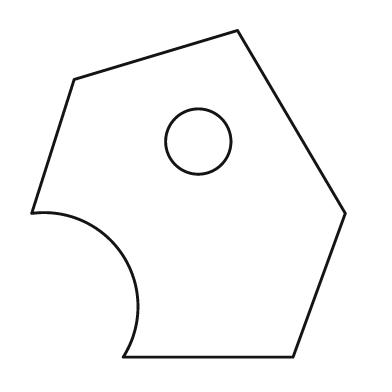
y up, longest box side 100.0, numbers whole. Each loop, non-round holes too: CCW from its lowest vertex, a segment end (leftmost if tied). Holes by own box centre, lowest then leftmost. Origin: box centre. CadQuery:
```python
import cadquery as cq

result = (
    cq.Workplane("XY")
    .moveTo(-20.0, -50.0)
    .lineTo(32.0, -50.0)
    .lineTo(48.0, -6.0)
    .lineTo(15.0, 50.0)
    .lineTo(-35.0, 35.0)
    .lineTo(-48.0, -6.0)
    .threePointArc((-20.0, -19.0), (-20.0, -50.0))
    .close()
    .moveTo(3.0, 16.0)
    .circle(10.0)
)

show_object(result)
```